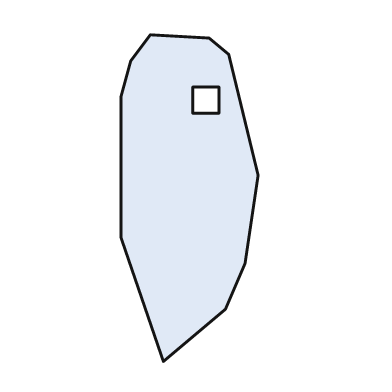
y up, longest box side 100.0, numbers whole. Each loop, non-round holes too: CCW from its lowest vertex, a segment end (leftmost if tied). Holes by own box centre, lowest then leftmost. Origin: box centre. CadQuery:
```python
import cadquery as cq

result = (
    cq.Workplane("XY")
    .moveTo(-8.0, -50.0)
    .lineTo(11.0, -34.0)
    .lineTo(17.0, -20.0)
    .lineTo(21.0, 7.0)
    .lineTo(12.0, 44.0)
    .lineTo(6.0, 49.0)
    .lineTo(-12.0, 50.0)
    .lineTo(-18.0, 42.0)
    .lineTo(-21.0, 31.0)
    .lineTo(-21.0, -12.0)
    .close()
    .moveTo(1.0, 26.0)
    .lineTo(9.0, 26.0)
    .lineTo(9.0, 34.0)
    .lineTo(1.0, 34.0)
    .close()
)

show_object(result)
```